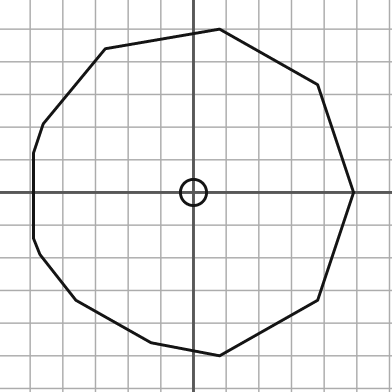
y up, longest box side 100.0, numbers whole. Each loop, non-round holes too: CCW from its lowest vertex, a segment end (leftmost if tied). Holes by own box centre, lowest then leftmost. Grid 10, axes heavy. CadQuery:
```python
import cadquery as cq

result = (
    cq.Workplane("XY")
    .moveTo(8.0, -50.0)
    .lineTo(38.0, -33.0)
    .lineTo(49.0, 0.0)
    .lineTo(38.0, 33.0)
    .lineTo(8.0, 50.0)
    .lineTo(-27.0, 44.0)
    .lineTo(-46.0, 21.0)
    .lineTo(-49.0, 12.0)
    .lineTo(-49.0, -14.0)
    .lineTo(-47.0, -19.0)
    .lineTo(-36.0, -33.0)
    .lineTo(-13.0, -46.0)
    .close()
    .moveTo(0.0, 0.0)
    .circle(4.0)
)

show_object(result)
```